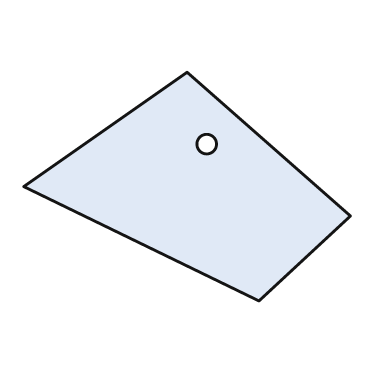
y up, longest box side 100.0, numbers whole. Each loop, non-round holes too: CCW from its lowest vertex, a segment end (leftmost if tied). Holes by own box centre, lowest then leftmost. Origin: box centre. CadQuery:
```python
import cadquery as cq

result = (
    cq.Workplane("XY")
    .moveTo(22.0, -35.0)
    .lineTo(50.0, -9.0)
    .lineTo(0.0, 35.0)
    .lineTo(-50.0, 0.0)
    .close()
    .moveTo(6.0, 13.0)
    .circle(3.0)
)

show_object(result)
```